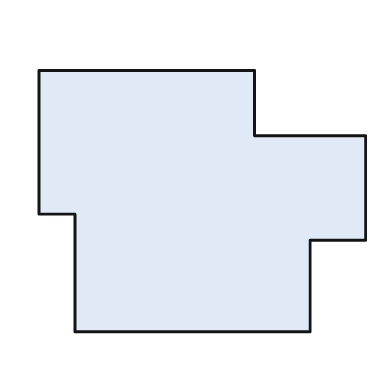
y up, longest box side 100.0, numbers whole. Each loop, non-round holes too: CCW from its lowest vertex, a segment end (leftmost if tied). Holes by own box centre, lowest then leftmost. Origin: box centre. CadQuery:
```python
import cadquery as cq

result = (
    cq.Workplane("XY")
    .moveTo(-39.0, -40.0)
    .lineTo(33.0, -40.0)
    .lineTo(33.0, -12.0)
    .lineTo(50.0, -12.0)
    .lineTo(50.0, 20.0)
    .lineTo(16.0, 20.0)
    .lineTo(16.0, 40.0)
    .lineTo(-50.0, 40.0)
    .lineTo(-50.0, -4.0)
    .lineTo(-39.0, -4.0)
    .close()
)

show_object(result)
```